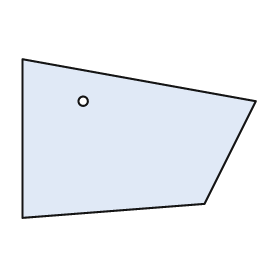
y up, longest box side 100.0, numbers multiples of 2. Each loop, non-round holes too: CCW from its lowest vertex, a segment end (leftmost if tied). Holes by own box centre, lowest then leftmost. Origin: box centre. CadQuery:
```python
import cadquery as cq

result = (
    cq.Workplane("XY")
    .moveTo(-50.0, -34.0)
    .lineTo(28.0, -28.0)
    .lineTo(50.0, 16.0)
    .lineTo(-50.0, 34.0)
    .close()
    .moveTo(-24.0, 16.0)
    .circle(2.0)
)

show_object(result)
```